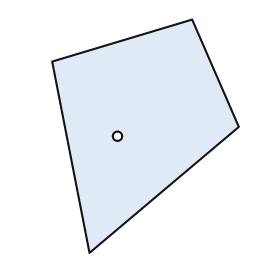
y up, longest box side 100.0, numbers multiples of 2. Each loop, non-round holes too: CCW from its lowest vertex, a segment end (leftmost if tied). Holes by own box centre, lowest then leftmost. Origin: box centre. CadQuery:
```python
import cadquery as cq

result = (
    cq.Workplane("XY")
    .moveTo(-24.0, -50.0)
    .lineTo(40.0, 4.0)
    .lineTo(20.0, 50.0)
    .lineTo(-40.0, 32.0)
    .close()
    .moveTo(-12.0, 0.0)
    .circle(2.0)
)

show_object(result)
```